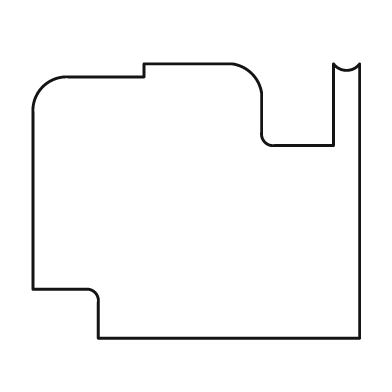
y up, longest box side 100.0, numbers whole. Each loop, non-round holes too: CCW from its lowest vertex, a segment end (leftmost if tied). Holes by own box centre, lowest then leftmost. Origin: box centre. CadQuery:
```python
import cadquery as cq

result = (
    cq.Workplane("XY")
    .moveTo(-30.0, -42.0)
    .lineTo(50.0, -42.0)
    .lineTo(50.0, 42.0)
    .threePointArc((46.0, 40.0), (42.0, 42.0))
    .lineTo(42.0, 17.0)
    .lineTo(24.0, 17.0)
    .threePointArc((21.0, 18.0), (20.0, 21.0))
    .lineTo(20.0, 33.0)
    .threePointArc((17.0, 39.0), (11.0, 42.0))
    .lineTo(-16.0, 42.0)
    .lineTo(-16.0, 38.0)
    .lineTo(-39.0, 38.0)
    .threePointArc((-47.0, 35.0), (-50.0, 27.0))
    .lineTo(-50.0, -27.0)
    .lineTo(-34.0, -27.0)
    .threePointArc((-31.0, -28.0), (-30.0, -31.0))
    .close()
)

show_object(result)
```